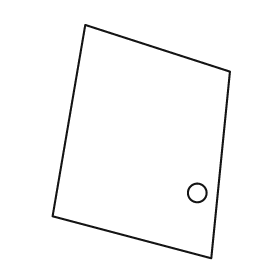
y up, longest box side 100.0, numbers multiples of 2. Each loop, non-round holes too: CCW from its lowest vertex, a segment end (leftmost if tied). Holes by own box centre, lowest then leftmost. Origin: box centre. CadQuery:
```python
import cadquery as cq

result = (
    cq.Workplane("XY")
    .moveTo(30.0, -50.0)
    .lineTo(38.0, 30.0)
    .lineTo(-24.0, 50.0)
    .lineTo(-38.0, -32.0)
    .close()
    .moveTo(24.0, -22.0)
    .circle(4.0)
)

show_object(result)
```